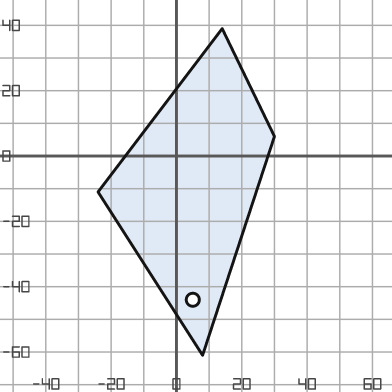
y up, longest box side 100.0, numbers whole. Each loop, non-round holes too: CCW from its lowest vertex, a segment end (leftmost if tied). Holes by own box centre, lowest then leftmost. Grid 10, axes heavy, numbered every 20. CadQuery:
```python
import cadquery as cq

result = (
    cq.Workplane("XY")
    .moveTo(8.0, -61.0)
    .lineTo(30.0, 6.0)
    .lineTo(14.0, 39.0)
    .lineTo(-24.0, -11.0)
    .close()
    .moveTo(5.0, -44.0)
    .circle(2.0)
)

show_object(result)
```